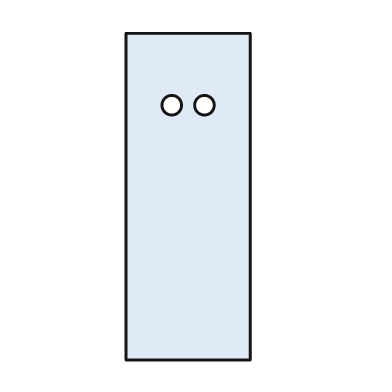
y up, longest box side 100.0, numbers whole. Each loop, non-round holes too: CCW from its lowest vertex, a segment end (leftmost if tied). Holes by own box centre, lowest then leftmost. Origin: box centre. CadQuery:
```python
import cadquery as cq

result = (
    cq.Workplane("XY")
    .moveTo(-19.0, -50.0)
    .lineTo(19.0, -50.0)
    .lineTo(19.0, 50.0)
    .lineTo(-19.0, 50.0)
    .close()
    .moveTo(-5.0, 28.0)
    .circle(3.0)
    .moveTo(5.0, 28.0)
    .circle(3.0)
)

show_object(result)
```